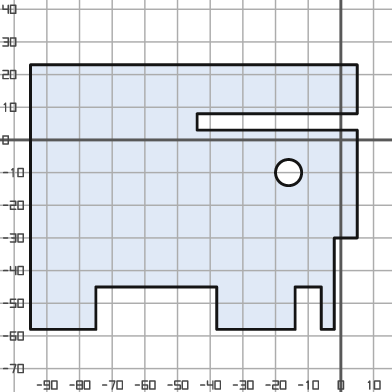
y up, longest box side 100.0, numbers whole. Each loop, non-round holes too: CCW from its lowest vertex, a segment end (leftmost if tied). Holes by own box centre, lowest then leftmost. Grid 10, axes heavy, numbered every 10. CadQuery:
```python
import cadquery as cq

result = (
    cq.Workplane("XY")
    .moveTo(-95.0, -58.0)
    .lineTo(-75.0, -58.0)
    .lineTo(-75.0, -45.0)
    .lineTo(-38.0, -45.0)
    .lineTo(-38.0, -58.0)
    .lineTo(-14.0, -58.0)
    .lineTo(-14.0, -45.0)
    .lineTo(-6.0, -45.0)
    .lineTo(-6.0, -58.0)
    .lineTo(-2.0, -58.0)
    .lineTo(-2.0, -30.0)
    .lineTo(5.0, -30.0)
    .lineTo(5.0, 3.0)
    .lineTo(-44.0, 3.0)
    .lineTo(-44.0, 8.0)
    .lineTo(5.0, 8.0)
    .lineTo(5.0, 23.0)
    .lineTo(-95.0, 23.0)
    .close()
    .moveTo(-16.0, -10.0)
    .circle(4.0)
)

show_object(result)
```